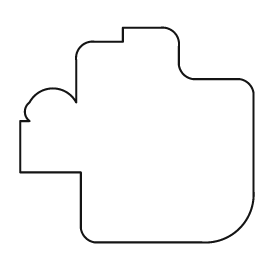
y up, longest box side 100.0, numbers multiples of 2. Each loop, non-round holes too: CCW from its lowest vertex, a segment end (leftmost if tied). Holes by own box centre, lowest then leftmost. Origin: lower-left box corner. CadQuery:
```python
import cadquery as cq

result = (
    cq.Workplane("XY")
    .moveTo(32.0, 0.0)
    .lineTo(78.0, 0.0)
    .threePointArc((94.0, 6.0), (100.0, 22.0))
    .lineTo(100.0, 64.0)
    .threePointArc((98.0, 68.0), (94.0, 70.0))
    .lineTo(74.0, 70.0)
    .threePointArc((70.0, 72.0), (68.0, 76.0))
    .lineTo(68.0, 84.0)
    .threePointArc((66.0, 90.0), (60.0, 92.0))
    .lineTo(44.0, 92.0)
    .lineTo(44.0, 86.0)
    .lineTo(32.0, 86.0)
    .threePointArc((26.0, 84.0), (24.0, 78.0))
    .lineTo(24.0, 60.0)
    .threePointArc((14.0, 66.0), (4.0, 60.0))
    .threePointArc((2.0, 56.0), (4.0, 52.0))
    .lineTo(0.0, 52.0)
    .lineTo(0.0, 30.0)
    .lineTo(26.0, 30.0)
    .lineTo(26.0, 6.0)
    .threePointArc((28.0, 2.0), (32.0, 0.0))
    .close()
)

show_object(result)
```